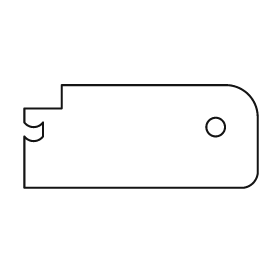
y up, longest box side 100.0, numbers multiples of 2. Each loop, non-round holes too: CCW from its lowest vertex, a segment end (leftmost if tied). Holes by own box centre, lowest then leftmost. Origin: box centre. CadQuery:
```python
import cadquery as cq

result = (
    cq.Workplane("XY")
    .moveTo(-50.0, -22.0)
    .lineTo(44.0, -22.0)
    .threePointArc((48.0, -20.0), (50.0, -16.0))
    .lineTo(50.0, 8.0)
    .threePointArc((46.0, 18.0), (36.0, 22.0))
    .lineTo(-34.0, 22.0)
    .lineTo(-34.0, 12.0)
    .lineTo(-50.0, 12.0)
    .lineTo(-50.0, 6.0)
    .threePointArc((-46.0, 4.0), (-42.0, 6.0))
    .lineTo(-42.0, 0.0)
    .threePointArc((-46.0, -2.0), (-50.0, 0.0))
    .close()
    .moveTo(32.0, 4.0)
    .circle(4.0)
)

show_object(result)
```